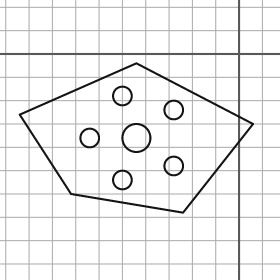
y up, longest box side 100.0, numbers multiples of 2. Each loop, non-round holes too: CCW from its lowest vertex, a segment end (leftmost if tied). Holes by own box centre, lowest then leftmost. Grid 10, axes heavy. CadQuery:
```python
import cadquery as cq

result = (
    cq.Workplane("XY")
    .moveTo(-24.0, -68.0)
    .lineTo(6.0, -30.0)
    .lineTo(-44.0, -4.0)
    .lineTo(-94.0, -26.0)
    .lineTo(-72.0, -60.0)
    .close()
    .moveTo(-50.0, -54.0)
    .circle(4.0)
    .moveTo(-28.0, -48.0)
    .circle(4.0)
    .moveTo(-64.0, -36.0)
    .circle(4.0)
    .moveTo(-44.0, -36.0)
    .circle(6.0)
    .moveTo(-28.0, -24.0)
    .circle(4.0)
    .moveTo(-50.0, -18.0)
    .circle(4.0)
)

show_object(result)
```